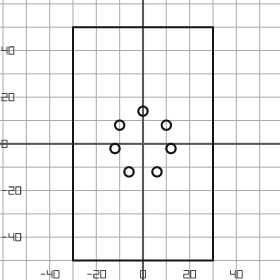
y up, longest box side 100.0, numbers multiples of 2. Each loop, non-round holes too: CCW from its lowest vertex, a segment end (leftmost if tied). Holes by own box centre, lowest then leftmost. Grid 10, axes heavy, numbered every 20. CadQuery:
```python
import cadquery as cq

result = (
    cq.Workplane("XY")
    .moveTo(-30.0, -50.0)
    .lineTo(30.0, -50.0)
    .lineTo(30.0, 50.0)
    .lineTo(-30.0, 50.0)
    .close()
    .moveTo(-6.0, -12.0)
    .circle(2.0)
    .moveTo(6.0, -12.0)
    .circle(2.0)
    .moveTo(-12.0, -2.0)
    .circle(2.0)
    .moveTo(12.0, -2.0)
    .circle(2.0)
    .moveTo(-10.0, 8.0)
    .circle(2.0)
    .moveTo(10.0, 8.0)
    .circle(2.0)
    .moveTo(0.0, 14.0)
    .circle(2.0)
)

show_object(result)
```